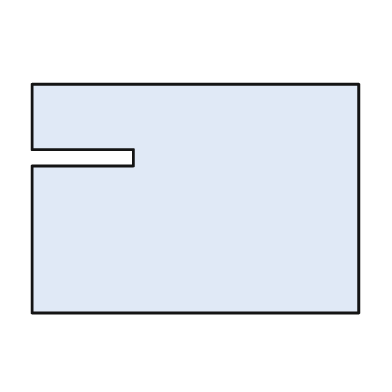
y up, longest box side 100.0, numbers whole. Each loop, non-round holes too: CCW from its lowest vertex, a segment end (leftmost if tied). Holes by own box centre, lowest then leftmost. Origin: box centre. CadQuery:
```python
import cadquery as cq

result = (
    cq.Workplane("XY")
    .moveTo(-50.0, -35.0)
    .lineTo(50.0, -35.0)
    .lineTo(50.0, 35.0)
    .lineTo(-50.0, 35.0)
    .lineTo(-50.0, 15.0)
    .lineTo(-19.0, 15.0)
    .lineTo(-19.0, 10.0)
    .lineTo(-50.0, 10.0)
    .close()
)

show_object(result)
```